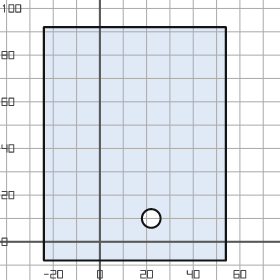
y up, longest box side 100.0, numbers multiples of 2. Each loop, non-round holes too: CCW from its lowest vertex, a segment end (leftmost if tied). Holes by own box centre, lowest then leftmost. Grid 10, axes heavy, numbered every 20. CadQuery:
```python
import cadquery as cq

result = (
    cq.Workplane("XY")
    .moveTo(-24.0, -8.0)
    .lineTo(54.0, -8.0)
    .lineTo(54.0, 92.0)
    .lineTo(-24.0, 92.0)
    .close()
    .moveTo(22.0, 10.0)
    .circle(4.0)
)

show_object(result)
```